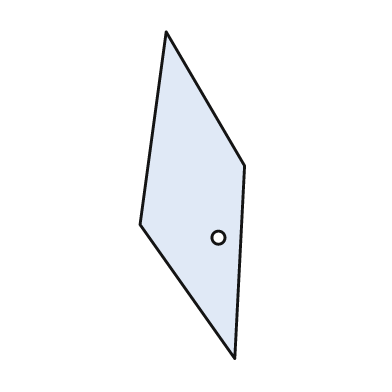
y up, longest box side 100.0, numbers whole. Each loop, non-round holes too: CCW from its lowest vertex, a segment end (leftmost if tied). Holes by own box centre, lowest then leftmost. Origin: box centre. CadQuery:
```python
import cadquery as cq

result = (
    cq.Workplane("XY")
    .moveTo(13.0, -50.0)
    .lineTo(16.0, 9.0)
    .lineTo(-8.0, 50.0)
    .lineTo(-16.0, -9.0)
    .close()
    .moveTo(8.0, -13.0)
    .circle(2.0)
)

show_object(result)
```